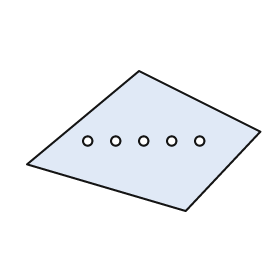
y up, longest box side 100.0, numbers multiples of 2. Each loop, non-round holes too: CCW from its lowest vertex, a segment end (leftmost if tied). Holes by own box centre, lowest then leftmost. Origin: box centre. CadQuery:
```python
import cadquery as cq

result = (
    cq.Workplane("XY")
    .moveTo(18.0, -30.0)
    .lineTo(50.0, 4.0)
    .lineTo(-2.0, 30.0)
    .lineTo(-50.0, -10.0)
    .close()
    .moveTo(-24.0, 0.0)
    .circle(2.0)
    .moveTo(-12.0, 0.0)
    .circle(2.0)
    .moveTo(0.0, 0.0)
    .circle(2.0)
    .moveTo(12.0, 0.0)
    .circle(2.0)
    .moveTo(24.0, 0.0)
    .circle(2.0)
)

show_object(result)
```